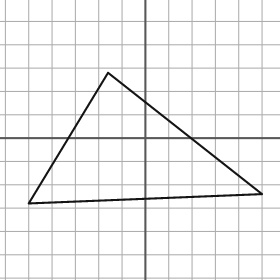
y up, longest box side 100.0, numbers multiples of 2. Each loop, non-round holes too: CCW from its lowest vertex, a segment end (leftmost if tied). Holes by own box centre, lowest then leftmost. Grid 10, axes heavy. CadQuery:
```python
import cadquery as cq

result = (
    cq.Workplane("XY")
    .moveTo(-50.0, -28.0)
    .lineTo(50.0, -24.0)
    .lineTo(-16.0, 28.0)
    .close()
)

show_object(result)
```